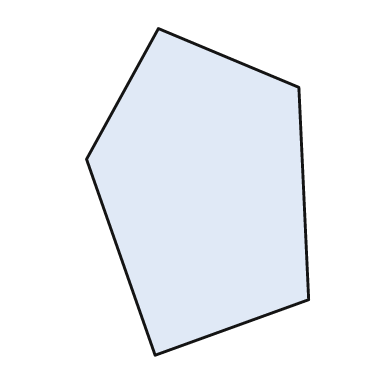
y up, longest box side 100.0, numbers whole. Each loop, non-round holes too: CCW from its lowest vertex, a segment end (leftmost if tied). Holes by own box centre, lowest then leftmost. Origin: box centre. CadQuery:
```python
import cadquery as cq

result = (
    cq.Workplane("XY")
    .moveTo(-13.0, -50.0)
    .lineTo(34.0, -33.0)
    .lineTo(31.0, 32.0)
    .lineTo(-12.0, 50.0)
    .lineTo(-34.0, 10.0)
    .close()
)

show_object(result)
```